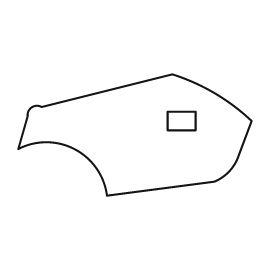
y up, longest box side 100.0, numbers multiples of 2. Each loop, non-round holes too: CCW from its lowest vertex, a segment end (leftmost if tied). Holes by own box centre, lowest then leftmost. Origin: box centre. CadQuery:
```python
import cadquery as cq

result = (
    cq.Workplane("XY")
    .moveTo(-12.0, -26.0)
    .lineTo(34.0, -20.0)
    .threePointArc((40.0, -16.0), (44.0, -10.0))
    .lineTo(50.0, 6.0)
    .threePointArc((34.0, 18.0), (16.0, 26.0))
    .lineTo(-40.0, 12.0)
    .threePointArc((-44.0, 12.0), (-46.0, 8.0))
    .lineTo(-50.0, -6.0)
    .threePointArc((-26.0, -6.0), (-12.0, -26.0))
    .close()
    .moveTo(14.0, 2.0)
    .lineTo(26.0, 2.0)
    .lineTo(26.0, 10.0)
    .lineTo(14.0, 10.0)
    .close()
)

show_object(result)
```